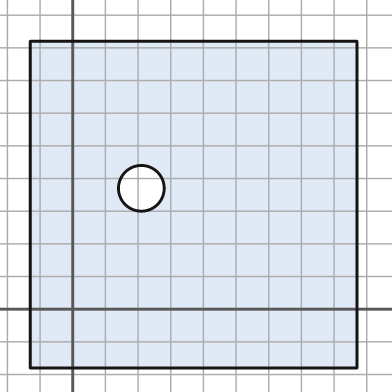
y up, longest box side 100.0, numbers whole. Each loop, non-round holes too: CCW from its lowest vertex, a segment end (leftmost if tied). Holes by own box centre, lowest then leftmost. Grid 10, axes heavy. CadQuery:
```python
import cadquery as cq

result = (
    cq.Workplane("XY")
    .moveTo(-13.0, -18.0)
    .lineTo(87.0, -18.0)
    .lineTo(87.0, 82.0)
    .lineTo(-13.0, 82.0)
    .close()
    .moveTo(21.0, 37.0)
    .circle(7.0)
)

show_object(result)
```